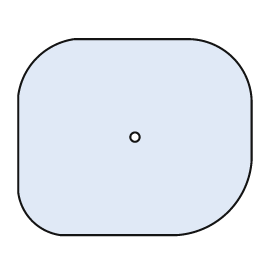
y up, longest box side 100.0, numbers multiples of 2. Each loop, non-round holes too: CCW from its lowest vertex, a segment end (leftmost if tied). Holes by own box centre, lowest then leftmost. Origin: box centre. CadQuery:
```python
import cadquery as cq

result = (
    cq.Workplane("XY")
    .moveTo(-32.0, -42.0)
    .lineTo(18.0, -42.0)
    .threePointArc((40.0, -32.0), (50.0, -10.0))
    .lineTo(50.0, 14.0)
    .threePointArc((42.0, 34.0), (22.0, 42.0))
    .lineTo(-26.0, 42.0)
    .threePointArc((-42.0, 34.0), (-50.0, 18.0))
    .lineTo(-50.0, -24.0)
    .threePointArc((-44.0, -36.0), (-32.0, -42.0))
    .close()
    .moveTo(0.0, 0.0)
    .circle(2.0)
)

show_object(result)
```